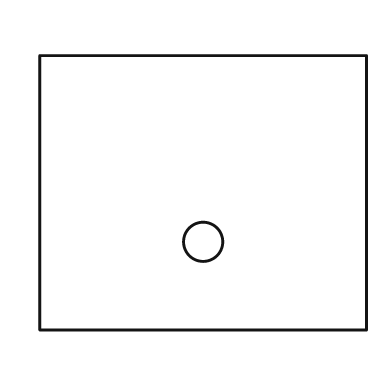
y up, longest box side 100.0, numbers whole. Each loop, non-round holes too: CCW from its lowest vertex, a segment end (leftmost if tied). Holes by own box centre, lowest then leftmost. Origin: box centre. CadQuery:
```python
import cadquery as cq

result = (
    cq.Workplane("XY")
    .moveTo(-50.0, -42.0)
    .lineTo(50.0, -42.0)
    .lineTo(50.0, 42.0)
    .lineTo(-50.0, 42.0)
    .close()
    .moveTo(0.0, -15.0)
    .circle(6.0)
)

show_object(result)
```